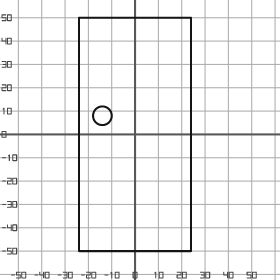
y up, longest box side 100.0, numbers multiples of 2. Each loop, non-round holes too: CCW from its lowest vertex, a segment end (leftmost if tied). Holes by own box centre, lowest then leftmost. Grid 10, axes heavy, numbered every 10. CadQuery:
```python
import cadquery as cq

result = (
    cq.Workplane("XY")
    .moveTo(-24.0, -50.0)
    .lineTo(24.0, -50.0)
    .lineTo(24.0, 50.0)
    .lineTo(-24.0, 50.0)
    .close()
    .moveTo(-14.0, 8.0)
    .circle(4.0)
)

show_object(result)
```